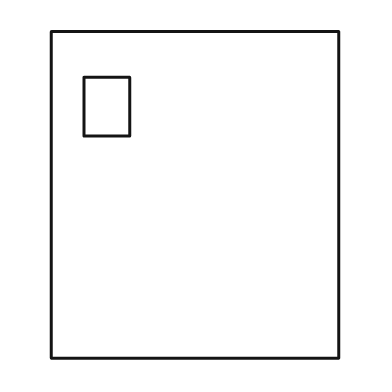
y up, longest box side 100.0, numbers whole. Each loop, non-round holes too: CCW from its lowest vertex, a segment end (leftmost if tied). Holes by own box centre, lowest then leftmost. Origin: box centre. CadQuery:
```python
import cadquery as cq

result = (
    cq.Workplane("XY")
    .moveTo(-44.0, -50.0)
    .lineTo(44.0, -50.0)
    .lineTo(44.0, 50.0)
    .lineTo(-44.0, 50.0)
    .close()
    .moveTo(-34.0, 18.0)
    .lineTo(-20.0, 18.0)
    .lineTo(-20.0, 36.0)
    .lineTo(-34.0, 36.0)
    .close()
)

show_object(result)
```